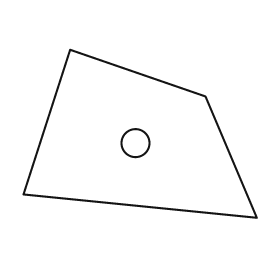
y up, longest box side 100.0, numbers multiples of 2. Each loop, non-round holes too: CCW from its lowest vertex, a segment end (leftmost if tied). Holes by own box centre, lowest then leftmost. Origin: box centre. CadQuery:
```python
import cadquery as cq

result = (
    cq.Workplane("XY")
    .moveTo(50.0, -36.0)
    .lineTo(28.0, 16.0)
    .lineTo(-30.0, 36.0)
    .lineTo(-50.0, -26.0)
    .close()
    .moveTo(-2.0, -4.0)
    .circle(6.0)
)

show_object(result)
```